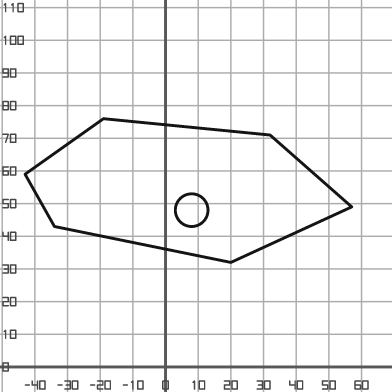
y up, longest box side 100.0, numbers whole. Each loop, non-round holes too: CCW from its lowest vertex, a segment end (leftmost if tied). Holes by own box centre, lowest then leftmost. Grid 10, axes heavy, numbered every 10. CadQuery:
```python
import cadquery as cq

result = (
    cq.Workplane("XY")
    .moveTo(20.0, 32.0)
    .lineTo(57.0, 49.0)
    .lineTo(32.0, 71.0)
    .lineTo(-19.0, 76.0)
    .lineTo(-43.0, 59.0)
    .lineTo(-34.0, 43.0)
    .close()
    .moveTo(8.0, 48.0)
    .circle(5.0)
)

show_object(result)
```